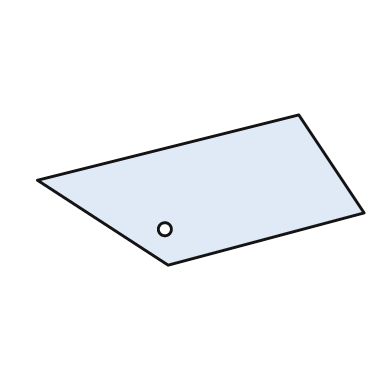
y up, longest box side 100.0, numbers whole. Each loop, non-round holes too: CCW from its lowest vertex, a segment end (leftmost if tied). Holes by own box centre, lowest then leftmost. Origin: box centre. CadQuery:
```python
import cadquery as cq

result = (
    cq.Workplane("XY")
    .moveTo(-10.0, -23.0)
    .lineTo(50.0, -7.0)
    .lineTo(30.0, 23.0)
    .lineTo(-50.0, 3.0)
    .close()
    .moveTo(-11.0, -12.0)
    .circle(2.0)
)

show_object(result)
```